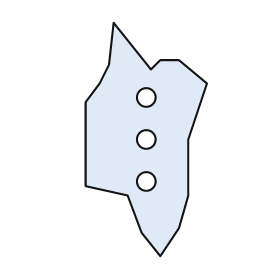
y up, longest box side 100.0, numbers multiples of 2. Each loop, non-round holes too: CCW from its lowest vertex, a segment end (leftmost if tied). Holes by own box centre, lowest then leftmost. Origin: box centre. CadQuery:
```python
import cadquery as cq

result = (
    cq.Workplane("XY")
    .moveTo(6.0, -50.0)
    .lineTo(14.0, -38.0)
    .lineTo(18.0, -24.0)
    .lineTo(18.0, 0.0)
    .lineTo(26.0, 24.0)
    .lineTo(14.0, 34.0)
    .lineTo(6.0, 34.0)
    .lineTo(2.0, 30.0)
    .lineTo(-14.0, 50.0)
    .lineTo(-16.0, 32.0)
    .lineTo(-20.0, 24.0)
    .lineTo(-26.0, 16.0)
    .lineTo(-26.0, -20.0)
    .lineTo(-8.0, -24.0)
    .lineTo(-2.0, -40.0)
    .close()
    .moveTo(0.0, -18.0)
    .circle(4.0)
    .moveTo(0.0, 0.0)
    .circle(4.0)
    .moveTo(0.0, 18.0)
    .circle(4.0)
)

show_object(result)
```